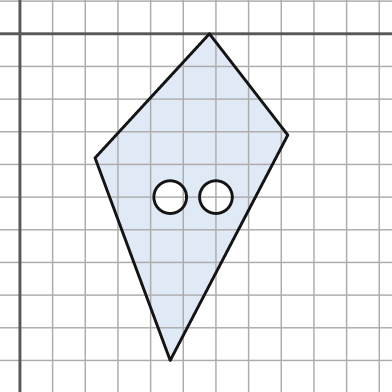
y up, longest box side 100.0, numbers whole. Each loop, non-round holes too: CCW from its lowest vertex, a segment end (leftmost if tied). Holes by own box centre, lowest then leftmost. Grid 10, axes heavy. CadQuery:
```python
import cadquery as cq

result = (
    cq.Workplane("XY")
    .moveTo(46.0, -100.0)
    .lineTo(82.0, -31.0)
    .lineTo(58.0, 0.0)
    .lineTo(23.0, -38.0)
    .close()
    .moveTo(46.0, -50.0)
    .circle(5.0)
    .moveTo(60.0, -50.0)
    .circle(5.0)
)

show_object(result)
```